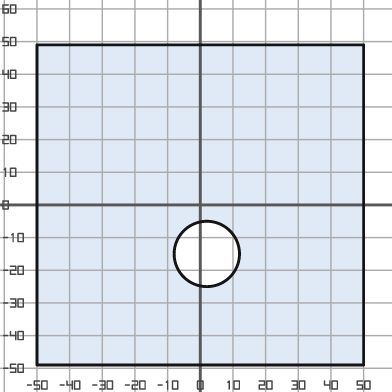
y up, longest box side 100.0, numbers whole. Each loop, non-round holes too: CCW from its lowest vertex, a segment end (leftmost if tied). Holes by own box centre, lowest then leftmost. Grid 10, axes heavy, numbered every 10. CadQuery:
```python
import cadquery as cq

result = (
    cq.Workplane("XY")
    .moveTo(-50.0, -49.0)
    .lineTo(50.0, -49.0)
    .lineTo(50.0, 49.0)
    .lineTo(-50.0, 49.0)
    .close()
    .moveTo(2.0, -15.0)
    .circle(10.0)
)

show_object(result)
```